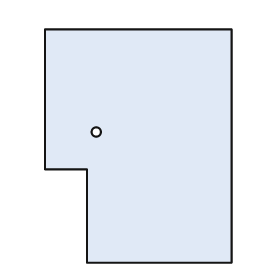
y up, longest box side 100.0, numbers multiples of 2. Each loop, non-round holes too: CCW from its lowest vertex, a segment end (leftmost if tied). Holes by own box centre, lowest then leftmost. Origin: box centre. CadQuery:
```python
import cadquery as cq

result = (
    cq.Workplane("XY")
    .moveTo(-22.0, -50.0)
    .lineTo(40.0, -50.0)
    .lineTo(40.0, 50.0)
    .lineTo(-40.0, 50.0)
    .lineTo(-40.0, -10.0)
    .lineTo(-22.0, -10.0)
    .close()
    .moveTo(-18.0, 6.0)
    .circle(2.0)
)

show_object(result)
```